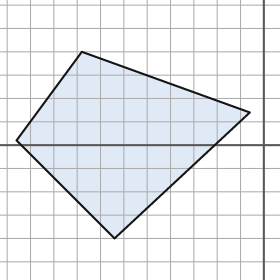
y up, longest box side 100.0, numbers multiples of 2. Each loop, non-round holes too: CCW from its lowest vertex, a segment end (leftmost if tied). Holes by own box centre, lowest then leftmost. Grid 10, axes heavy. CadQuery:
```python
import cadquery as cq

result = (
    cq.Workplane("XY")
    .moveTo(-64.0, -40.0)
    .lineTo(-6.0, 14.0)
    .lineTo(-78.0, 40.0)
    .lineTo(-106.0, 2.0)
    .close()
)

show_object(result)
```